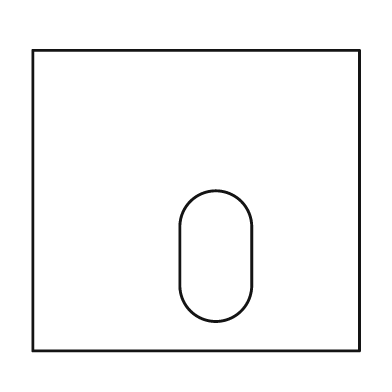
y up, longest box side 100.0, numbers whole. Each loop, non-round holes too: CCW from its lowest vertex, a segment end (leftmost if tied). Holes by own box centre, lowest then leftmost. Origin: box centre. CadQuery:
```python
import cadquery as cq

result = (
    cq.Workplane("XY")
    .moveTo(-50.0, -46.0)
    .lineTo(50.0, -46.0)
    .lineTo(50.0, 46.0)
    .lineTo(-50.0, 46.0)
    .close()
    .moveTo(-5.0, -26.0)
    .threePointArc((6.0, -37.0), (17.0, -26.0))
    .lineTo(17.0, -8.0)
    .threePointArc((6.0, 3.0), (-5.0, -8.0))
    .close()
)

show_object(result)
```